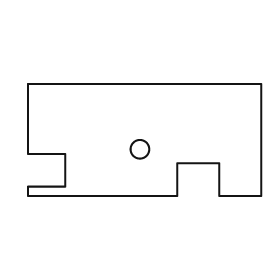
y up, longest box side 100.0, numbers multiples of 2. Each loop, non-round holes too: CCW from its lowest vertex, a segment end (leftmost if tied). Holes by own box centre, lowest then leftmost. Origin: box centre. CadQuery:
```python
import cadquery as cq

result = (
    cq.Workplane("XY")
    .moveTo(-50.0, -24.0)
    .lineTo(14.0, -24.0)
    .lineTo(14.0, -10.0)
    .lineTo(32.0, -10.0)
    .lineTo(32.0, -24.0)
    .lineTo(50.0, -24.0)
    .lineTo(50.0, 24.0)
    .lineTo(-50.0, 24.0)
    .lineTo(-50.0, -6.0)
    .lineTo(-34.0, -6.0)
    .lineTo(-34.0, -20.0)
    .lineTo(-50.0, -20.0)
    .close()
    .moveTo(-2.0, -4.0)
    .circle(4.0)
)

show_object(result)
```